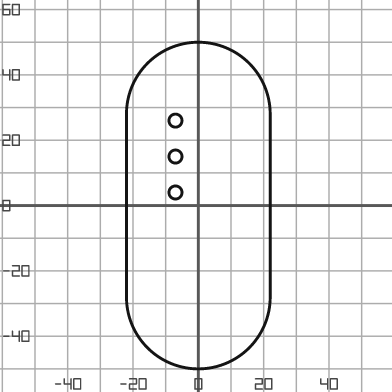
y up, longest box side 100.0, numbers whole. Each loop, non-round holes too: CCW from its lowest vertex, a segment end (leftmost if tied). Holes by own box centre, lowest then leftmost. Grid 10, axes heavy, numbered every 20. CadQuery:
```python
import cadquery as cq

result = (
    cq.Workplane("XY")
    .moveTo(-22.0, -28.0)
    .threePointArc((0.0, -50.0), (22.0, -28.0))
    .lineTo(22.0, 28.0)
    .threePointArc((0.0, 50.0), (-22.0, 28.0))
    .close()
    .moveTo(-7.0, 4.0)
    .circle(2.0)
    .moveTo(-7.0, 15.0)
    .circle(2.0)
    .moveTo(-7.0, 26.0)
    .circle(2.0)
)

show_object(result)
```